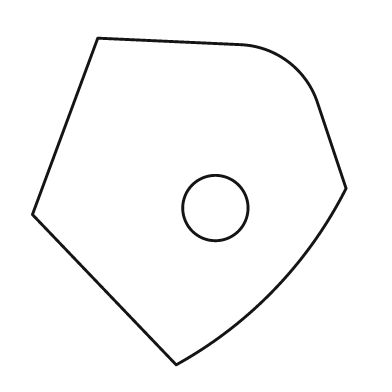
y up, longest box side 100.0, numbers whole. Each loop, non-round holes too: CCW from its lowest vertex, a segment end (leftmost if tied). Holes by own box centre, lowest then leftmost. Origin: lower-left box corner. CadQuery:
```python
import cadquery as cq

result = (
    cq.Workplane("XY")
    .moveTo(44.0, 0.0)
    .threePointArc((74.0, 23.0), (96.0, 54.0))
    .lineTo(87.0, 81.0)
    .threePointArc((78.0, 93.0), (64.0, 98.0))
    .lineTo(20.0, 100.0)
    .lineTo(0.0, 46.0)
    .close()
    .moveTo(56.0, 48.0)
    .circle(10.0)
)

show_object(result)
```